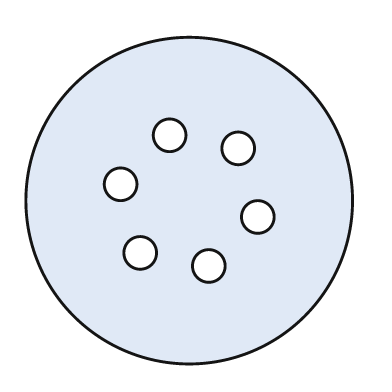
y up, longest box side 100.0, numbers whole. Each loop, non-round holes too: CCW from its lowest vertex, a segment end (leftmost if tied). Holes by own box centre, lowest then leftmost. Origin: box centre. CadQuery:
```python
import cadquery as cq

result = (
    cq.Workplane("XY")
    .moveTo(0.0, 0.0)
    .circle(50.0)
    .moveTo(6.0, -20.0)
    .circle(5.0)
    .moveTo(-15.0, -16.0)
    .circle(5.0)
    .moveTo(21.0, -5.0)
    .circle(5.0)
    .moveTo(-21.0, 5.0)
    .circle(5.0)
    .moveTo(15.0, 16.0)
    .circle(5.0)
    .moveTo(-6.0, 20.0)
    .circle(5.0)
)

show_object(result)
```